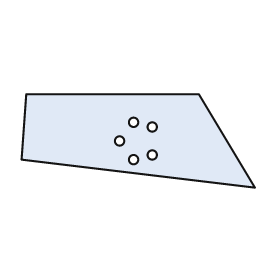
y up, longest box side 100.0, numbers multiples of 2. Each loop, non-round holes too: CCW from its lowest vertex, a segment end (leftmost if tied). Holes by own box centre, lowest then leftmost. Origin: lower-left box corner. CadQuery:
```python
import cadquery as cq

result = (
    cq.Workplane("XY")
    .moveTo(100.0, 0.0)
    .lineTo(76.0, 40.0)
    .lineTo(2.0, 40.0)
    .lineTo(0.0, 12.0)
    .close()
    .moveTo(48.0, 12.0)
    .circle(2.0)
    .moveTo(56.0, 14.0)
    .circle(2.0)
    .moveTo(42.0, 20.0)
    .circle(2.0)
    .moveTo(56.0, 26.0)
    .circle(2.0)
    .moveTo(48.0, 28.0)
    .circle(2.0)
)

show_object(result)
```